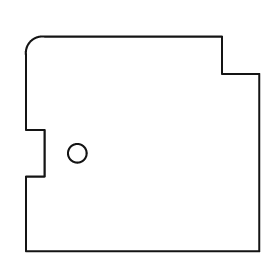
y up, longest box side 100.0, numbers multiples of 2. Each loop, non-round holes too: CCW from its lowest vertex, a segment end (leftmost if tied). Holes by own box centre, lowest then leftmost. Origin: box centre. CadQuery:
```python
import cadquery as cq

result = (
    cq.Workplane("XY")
    .moveTo(-50.0, -46.0)
    .lineTo(50.0, -46.0)
    .lineTo(50.0, 30.0)
    .lineTo(34.0, 30.0)
    .lineTo(34.0, 46.0)
    .lineTo(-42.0, 46.0)
    .threePointArc((-48.0, 44.0), (-50.0, 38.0))
    .lineTo(-50.0, 6.0)
    .lineTo(-42.0, 6.0)
    .lineTo(-42.0, -14.0)
    .lineTo(-50.0, -14.0)
    .close()
    .moveTo(-28.0, -4.0)
    .circle(4.0)
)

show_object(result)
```